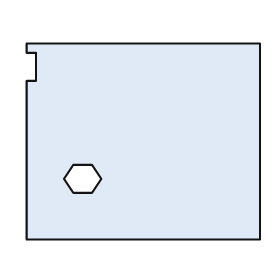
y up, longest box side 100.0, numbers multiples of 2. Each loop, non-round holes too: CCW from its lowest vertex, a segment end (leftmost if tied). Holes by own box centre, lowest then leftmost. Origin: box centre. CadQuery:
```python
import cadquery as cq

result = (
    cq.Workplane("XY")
    .moveTo(-50.0, -42.0)
    .lineTo(50.0, -42.0)
    .lineTo(50.0, 42.0)
    .lineTo(-50.0, 42.0)
    .lineTo(-50.0, 38.0)
    .lineTo(-46.0, 38.0)
    .lineTo(-46.0, 26.0)
    .lineTo(-50.0, 26.0)
    .close()
    .moveTo(-30.0, -22.0)
    .lineTo(-22.0, -22.0)
    .lineTo(-18.0, -16.0)
    .lineTo(-22.0, -10.0)
    .lineTo(-30.0, -10.0)
    .lineTo(-34.0, -16.0)
    .close()
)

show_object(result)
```